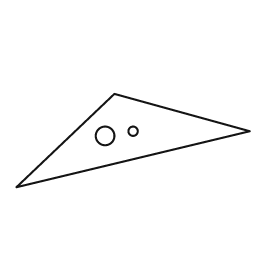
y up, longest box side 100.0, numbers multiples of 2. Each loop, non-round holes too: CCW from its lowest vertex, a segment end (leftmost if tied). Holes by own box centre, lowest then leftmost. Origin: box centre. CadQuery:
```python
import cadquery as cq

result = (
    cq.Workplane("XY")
    .moveTo(-50.0, -20.0)
    .lineTo(50.0, 4.0)
    .lineTo(-8.0, 20.0)
    .close()
    .moveTo(-12.0, 2.0)
    .circle(4.0)
    .moveTo(0.0, 4.0)
    .circle(2.0)
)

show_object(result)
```